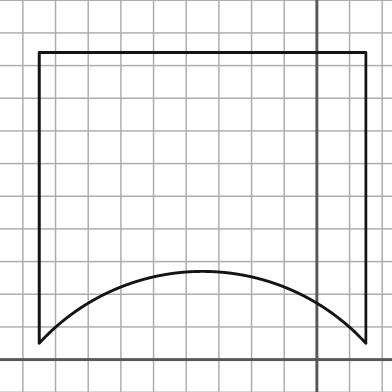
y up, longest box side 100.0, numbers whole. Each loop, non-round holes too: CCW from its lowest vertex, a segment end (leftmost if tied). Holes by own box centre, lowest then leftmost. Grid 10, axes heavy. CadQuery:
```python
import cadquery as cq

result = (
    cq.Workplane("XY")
    .moveTo(-85.0, 5.0)
    .threePointArc((-35.0, 27.0), (15.0, 5.0))
    .lineTo(15.0, 94.0)
    .lineTo(-85.0, 94.0)
    .close()
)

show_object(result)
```